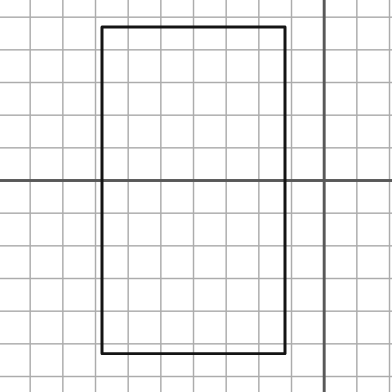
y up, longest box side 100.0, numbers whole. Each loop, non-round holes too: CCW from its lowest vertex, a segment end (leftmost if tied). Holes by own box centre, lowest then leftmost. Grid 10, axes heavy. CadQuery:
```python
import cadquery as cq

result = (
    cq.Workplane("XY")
    .moveTo(-68.0, -53.0)
    .lineTo(-12.0, -53.0)
    .lineTo(-12.0, 47.0)
    .lineTo(-68.0, 47.0)
    .close()
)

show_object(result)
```